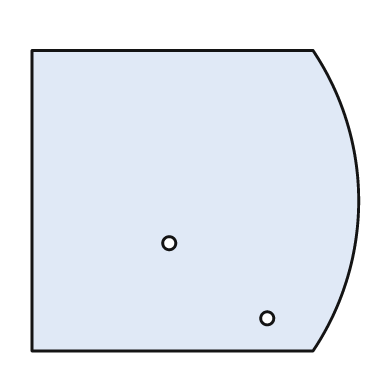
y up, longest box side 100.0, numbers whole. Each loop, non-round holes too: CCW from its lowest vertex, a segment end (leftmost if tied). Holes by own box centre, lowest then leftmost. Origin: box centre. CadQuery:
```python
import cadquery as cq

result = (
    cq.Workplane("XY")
    .moveTo(-50.0, -46.0)
    .lineTo(36.0, -46.0)
    .threePointArc((50.0, 0.0), (36.0, 46.0))
    .lineTo(-50.0, 46.0)
    .close()
    .moveTo(22.0, -36.0)
    .circle(2.0)
    .moveTo(-8.0, -13.0)
    .circle(2.0)
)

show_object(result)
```